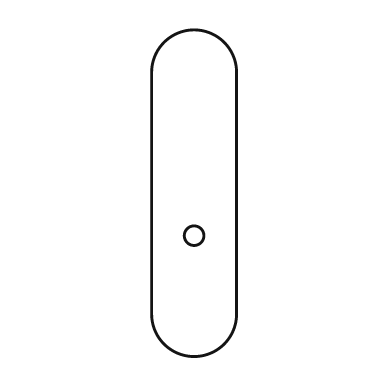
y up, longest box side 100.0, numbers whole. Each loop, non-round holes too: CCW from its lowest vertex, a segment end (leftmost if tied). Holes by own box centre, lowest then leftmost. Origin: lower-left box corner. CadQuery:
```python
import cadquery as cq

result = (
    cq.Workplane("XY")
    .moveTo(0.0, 13.0)
    .threePointArc((13.0, 0.0), (26.0, 13.0))
    .lineTo(26.0, 87.0)
    .threePointArc((13.0, 100.0), (0.0, 87.0))
    .close()
    .moveTo(13.0, 37.0)
    .circle(3.0)
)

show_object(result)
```